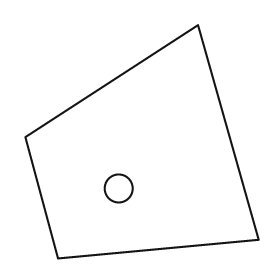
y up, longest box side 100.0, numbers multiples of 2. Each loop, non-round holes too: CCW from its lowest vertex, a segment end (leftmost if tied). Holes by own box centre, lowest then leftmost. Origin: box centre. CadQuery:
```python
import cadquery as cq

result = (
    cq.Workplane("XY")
    .moveTo(-36.0, -50.0)
    .lineTo(50.0, -42.0)
    .lineTo(24.0, 50.0)
    .lineTo(-50.0, 2.0)
    .close()
    .moveTo(-10.0, -20.0)
    .circle(6.0)
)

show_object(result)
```